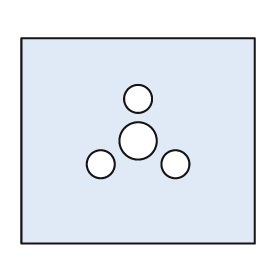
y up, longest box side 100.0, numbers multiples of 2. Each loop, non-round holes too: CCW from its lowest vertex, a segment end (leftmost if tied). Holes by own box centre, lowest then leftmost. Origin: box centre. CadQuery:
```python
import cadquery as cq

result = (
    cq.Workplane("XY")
    .moveTo(-50.0, -44.0)
    .lineTo(50.0, -44.0)
    .lineTo(50.0, 44.0)
    .lineTo(-50.0, 44.0)
    .close()
    .moveTo(-16.0, -10.0)
    .circle(6.0)
    .moveTo(16.0, -10.0)
    .circle(6.0)
    .moveTo(0.0, 0.0)
    .circle(8.0)
    .moveTo(0.0, 18.0)
    .circle(6.0)
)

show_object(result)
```